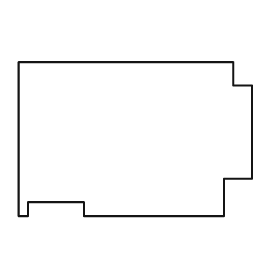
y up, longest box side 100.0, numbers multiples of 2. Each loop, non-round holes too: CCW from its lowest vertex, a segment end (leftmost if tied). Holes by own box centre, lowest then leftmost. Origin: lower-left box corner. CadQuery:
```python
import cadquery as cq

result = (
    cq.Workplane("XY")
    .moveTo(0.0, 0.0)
    .lineTo(4.0, 0.0)
    .lineTo(4.0, 6.0)
    .lineTo(28.0, 6.0)
    .lineTo(28.0, 0.0)
    .lineTo(88.0, 0.0)
    .lineTo(88.0, 16.0)
    .lineTo(100.0, 16.0)
    .lineTo(100.0, 56.0)
    .lineTo(92.0, 56.0)
    .lineTo(92.0, 66.0)
    .lineTo(0.0, 66.0)
    .close()
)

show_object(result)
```